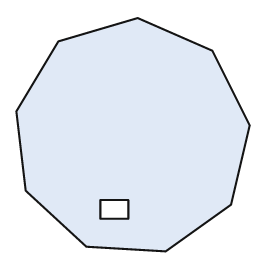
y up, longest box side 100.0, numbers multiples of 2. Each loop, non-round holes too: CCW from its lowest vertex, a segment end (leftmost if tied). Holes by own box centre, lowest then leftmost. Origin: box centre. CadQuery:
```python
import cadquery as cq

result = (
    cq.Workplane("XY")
    .moveTo(14.0, -50.0)
    .lineTo(42.0, -30.0)
    .lineTo(50.0, 4.0)
    .lineTo(34.0, 36.0)
    .lineTo(2.0, 50.0)
    .lineTo(-32.0, 40.0)
    .lineTo(-50.0, 10.0)
    .lineTo(-46.0, -24.0)
    .lineTo(-20.0, -48.0)
    .close()
    .moveTo(-14.0, -36.0)
    .lineTo(-2.0, -36.0)
    .lineTo(-2.0, -28.0)
    .lineTo(-14.0, -28.0)
    .close()
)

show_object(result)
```